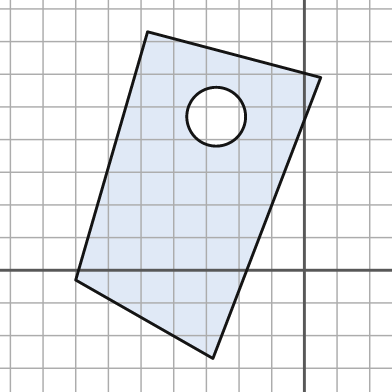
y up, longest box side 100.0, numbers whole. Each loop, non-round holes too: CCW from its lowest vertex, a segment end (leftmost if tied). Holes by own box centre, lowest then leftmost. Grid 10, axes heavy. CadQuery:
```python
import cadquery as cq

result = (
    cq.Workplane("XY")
    .moveTo(-28.0, -27.0)
    .lineTo(5.0, 59.0)
    .lineTo(-48.0, 73.0)
    .lineTo(-70.0, -3.0)
    .close()
    .moveTo(-27.0, 47.0)
    .circle(9.0)
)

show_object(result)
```